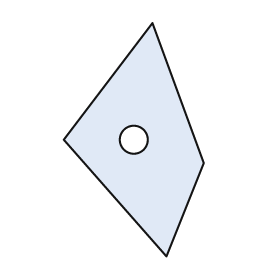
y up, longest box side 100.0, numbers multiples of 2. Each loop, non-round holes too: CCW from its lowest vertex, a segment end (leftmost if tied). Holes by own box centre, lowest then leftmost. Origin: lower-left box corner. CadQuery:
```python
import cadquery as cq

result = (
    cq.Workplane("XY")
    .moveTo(44.0, 0.0)
    .lineTo(60.0, 40.0)
    .lineTo(38.0, 100.0)
    .lineTo(0.0, 50.0)
    .close()
    .moveTo(30.0, 50.0)
    .circle(6.0)
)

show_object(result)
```